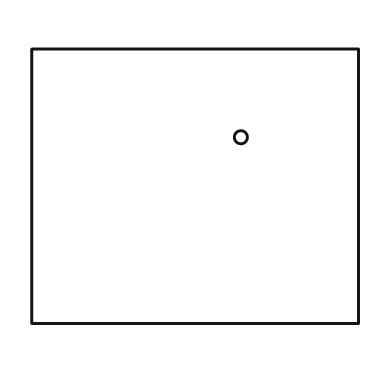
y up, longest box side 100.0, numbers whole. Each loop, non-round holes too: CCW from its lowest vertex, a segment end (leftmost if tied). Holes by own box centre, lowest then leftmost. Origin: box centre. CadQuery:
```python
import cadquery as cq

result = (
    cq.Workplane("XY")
    .moveTo(-50.0, -42.0)
    .lineTo(50.0, -42.0)
    .lineTo(50.0, 42.0)
    .lineTo(-50.0, 42.0)
    .close()
    .moveTo(14.0, 15.0)
    .circle(2.0)
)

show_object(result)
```